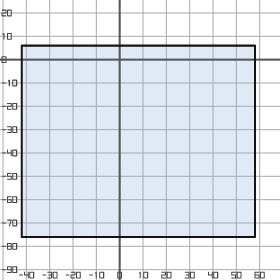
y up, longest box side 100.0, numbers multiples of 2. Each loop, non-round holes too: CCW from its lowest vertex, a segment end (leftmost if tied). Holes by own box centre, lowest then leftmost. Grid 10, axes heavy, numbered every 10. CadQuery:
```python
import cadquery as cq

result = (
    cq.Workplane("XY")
    .moveTo(-42.0, -76.0)
    .lineTo(58.0, -76.0)
    .lineTo(58.0, 6.0)
    .lineTo(-42.0, 6.0)
    .close()
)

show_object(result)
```